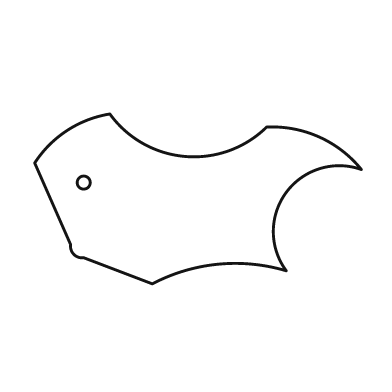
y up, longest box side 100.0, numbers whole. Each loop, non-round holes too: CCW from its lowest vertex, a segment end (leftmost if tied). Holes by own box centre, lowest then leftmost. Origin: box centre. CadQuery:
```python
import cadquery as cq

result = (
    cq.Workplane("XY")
    .moveTo(-14.0, -26.0)
    .threePointArc((6.0, -20.0), (27.0, -22.0))
    .threePointArc((27.0, 2.0), (50.0, 9.0))
    .threePointArc((37.0, 19.0), (21.0, 22.0))
    .threePointArc((-4.0, 13.0), (-27.0, 26.0))
    .threePointArc((-40.0, 21.0), (-50.0, 11.0))
    .lineTo(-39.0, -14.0)
    .threePointArc((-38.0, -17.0), (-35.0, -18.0))
    .close()
    .moveTo(-35.0, 5.0)
    .circle(2.0)
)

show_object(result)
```